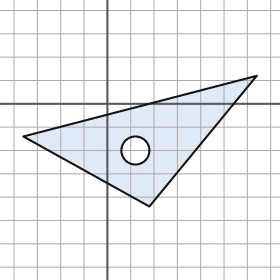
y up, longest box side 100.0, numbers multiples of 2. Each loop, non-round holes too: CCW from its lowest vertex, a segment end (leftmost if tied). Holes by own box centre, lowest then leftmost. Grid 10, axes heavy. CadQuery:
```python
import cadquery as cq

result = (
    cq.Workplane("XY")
    .moveTo(18.0, -44.0)
    .lineTo(64.0, 12.0)
    .lineTo(-36.0, -14.0)
    .close()
    .moveTo(12.0, -20.0)
    .circle(6.0)
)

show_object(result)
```